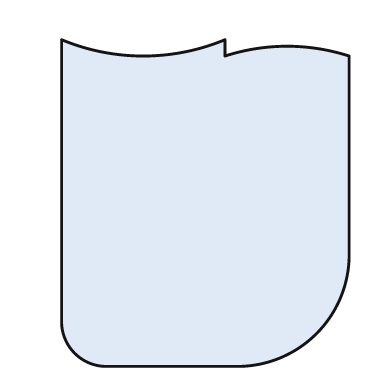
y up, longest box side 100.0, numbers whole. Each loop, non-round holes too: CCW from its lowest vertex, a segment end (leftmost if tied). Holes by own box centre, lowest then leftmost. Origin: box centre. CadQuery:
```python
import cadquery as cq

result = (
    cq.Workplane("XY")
    .moveTo(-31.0, -50.0)
    .lineTo(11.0, -50.0)
    .threePointArc((34.0, -40.0), (44.0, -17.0))
    .lineTo(44.0, 45.0)
    .threePointArc((25.0, 48.0), (6.0, 45.0))
    .lineTo(6.0, 50.0)
    .threePointArc((-19.0, 45.0), (-44.0, 50.0))
    .lineTo(-44.0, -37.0)
    .threePointArc((-40.0, -46.0), (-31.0, -50.0))
    .close()
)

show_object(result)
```